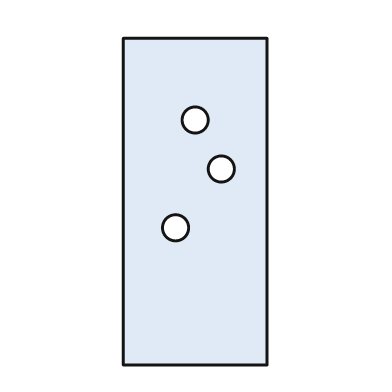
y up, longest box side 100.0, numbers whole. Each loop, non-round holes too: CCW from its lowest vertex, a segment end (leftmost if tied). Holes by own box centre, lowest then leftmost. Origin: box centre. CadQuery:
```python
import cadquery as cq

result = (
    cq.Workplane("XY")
    .moveTo(-22.0, -50.0)
    .lineTo(22.0, -50.0)
    .lineTo(22.0, 50.0)
    .lineTo(-22.0, 50.0)
    .close()
    .moveTo(-6.0, -8.0)
    .circle(4.0)
    .moveTo(8.0, 10.0)
    .circle(4.0)
    .moveTo(0.0, 25.0)
    .circle(4.0)
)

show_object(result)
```